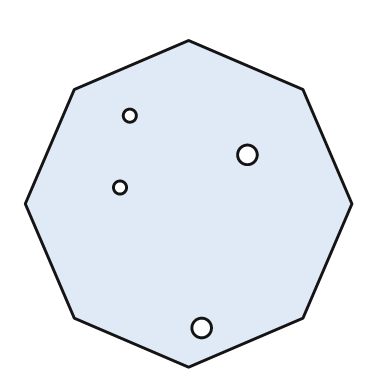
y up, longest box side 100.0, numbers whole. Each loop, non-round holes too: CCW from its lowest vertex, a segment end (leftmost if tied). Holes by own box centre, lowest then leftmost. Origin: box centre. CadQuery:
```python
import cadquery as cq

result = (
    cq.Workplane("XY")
    .moveTo(0.0, -50.0)
    .lineTo(35.0, -35.0)
    .lineTo(50.0, 0.0)
    .lineTo(35.0, 35.0)
    .lineTo(0.0, 50.0)
    .lineTo(-35.0, 35.0)
    .lineTo(-50.0, 0.0)
    .lineTo(-35.0, -35.0)
    .close()
    .moveTo(4.0, -38.0)
    .circle(3.0)
    .moveTo(-21.0, 5.0)
    .circle(2.0)
    .moveTo(18.0, 15.0)
    .circle(3.0)
    .moveTo(-18.0, 27.0)
    .circle(2.0)
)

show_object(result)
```